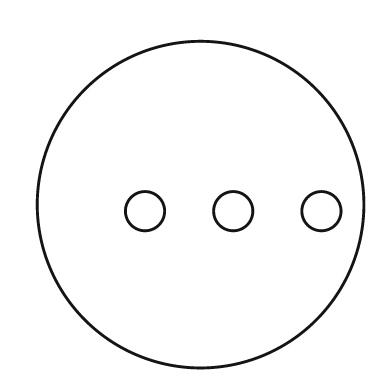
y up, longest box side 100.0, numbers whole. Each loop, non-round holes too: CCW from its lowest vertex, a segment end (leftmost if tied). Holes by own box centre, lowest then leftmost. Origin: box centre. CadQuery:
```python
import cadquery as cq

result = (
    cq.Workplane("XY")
    .moveTo(0.0, 0.0)
    .circle(50.0)
    .moveTo(-17.0, -2.0)
    .circle(6.0)
    .moveTo(10.0, -2.0)
    .circle(6.0)
    .moveTo(37.0, -2.0)
    .circle(6.0)
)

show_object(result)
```